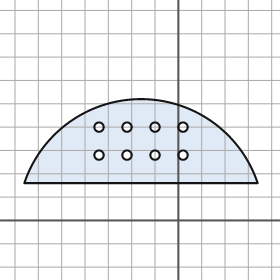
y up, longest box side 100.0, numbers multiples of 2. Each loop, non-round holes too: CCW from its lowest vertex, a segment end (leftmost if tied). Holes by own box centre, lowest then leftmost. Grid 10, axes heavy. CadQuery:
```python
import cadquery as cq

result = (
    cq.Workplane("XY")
    .moveTo(-66.0, 16.0)
    .lineTo(34.0, 16.0)
    .threePointArc((-16.0, 52.0), (-66.0, 16.0))
    .close()
    .moveTo(-34.0, 28.0)
    .circle(2.0)
    .moveTo(-22.0, 28.0)
    .circle(2.0)
    .moveTo(-10.0, 28.0)
    .circle(2.0)
    .moveTo(2.0, 28.0)
    .circle(2.0)
    .moveTo(-34.0, 40.0)
    .circle(2.0)
    .moveTo(-22.0, 40.0)
    .circle(2.0)
    .moveTo(-10.0, 40.0)
    .circle(2.0)
    .moveTo(2.0, 40.0)
    .circle(2.0)
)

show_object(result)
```